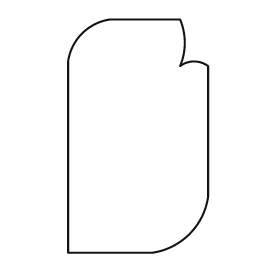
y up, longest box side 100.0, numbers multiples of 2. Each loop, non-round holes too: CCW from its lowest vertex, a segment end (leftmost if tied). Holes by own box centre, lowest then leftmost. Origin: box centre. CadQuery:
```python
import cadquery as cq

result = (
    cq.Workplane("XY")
    .moveTo(-30.0, -50.0)
    .lineTo(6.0, -50.0)
    .threePointArc((22.0, -42.0), (30.0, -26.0))
    .lineTo(30.0, 30.0)
    .threePointArc((24.0, 32.0), (18.0, 30.0))
    .threePointArc((20.0, 40.0), (18.0, 50.0))
    .lineTo(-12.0, 50.0)
    .threePointArc((-24.0, 44.0), (-30.0, 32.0))
    .close()
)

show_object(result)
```